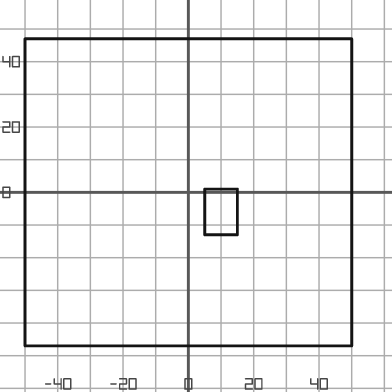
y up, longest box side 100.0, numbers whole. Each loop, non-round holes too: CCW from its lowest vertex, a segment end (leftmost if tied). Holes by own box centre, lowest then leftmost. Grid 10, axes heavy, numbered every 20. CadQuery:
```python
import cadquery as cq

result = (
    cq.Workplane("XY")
    .moveTo(-50.0, -47.0)
    .lineTo(50.0, -47.0)
    .lineTo(50.0, 47.0)
    .lineTo(-50.0, 47.0)
    .close()
    .moveTo(5.0, -13.0)
    .lineTo(15.0, -13.0)
    .lineTo(15.0, 1.0)
    .lineTo(5.0, 1.0)
    .close()
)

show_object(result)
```